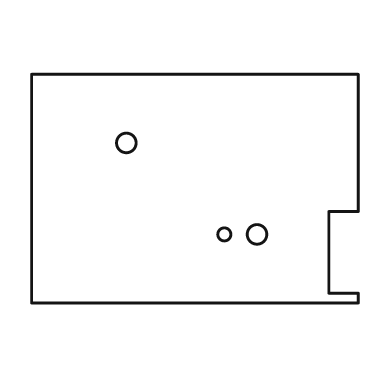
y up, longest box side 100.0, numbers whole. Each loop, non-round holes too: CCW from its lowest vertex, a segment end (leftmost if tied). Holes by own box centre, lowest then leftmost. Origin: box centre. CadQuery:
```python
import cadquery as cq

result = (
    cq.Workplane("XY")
    .moveTo(-50.0, -35.0)
    .lineTo(50.0, -35.0)
    .lineTo(50.0, -32.0)
    .lineTo(41.0, -32.0)
    .lineTo(41.0, -7.0)
    .lineTo(50.0, -7.0)
    .lineTo(50.0, 35.0)
    .lineTo(-50.0, 35.0)
    .close()
    .moveTo(9.0, -14.0)
    .circle(2.0)
    .moveTo(19.0, -14.0)
    .circle(3.0)
    .moveTo(-21.0, 14.0)
    .circle(3.0)
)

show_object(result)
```